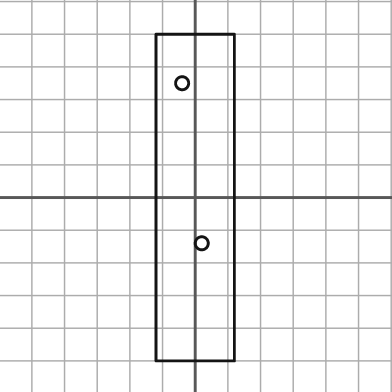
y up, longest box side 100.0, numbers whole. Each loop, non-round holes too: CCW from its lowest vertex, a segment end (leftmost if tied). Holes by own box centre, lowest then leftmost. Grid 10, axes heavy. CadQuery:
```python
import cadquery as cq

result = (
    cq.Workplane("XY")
    .moveTo(-12.0, -50.0)
    .lineTo(12.0, -50.0)
    .lineTo(12.0, 50.0)
    .lineTo(-12.0, 50.0)
    .close()
    .moveTo(2.0, -14.0)
    .circle(2.0)
    .moveTo(-4.0, 35.0)
    .circle(2.0)
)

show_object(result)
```